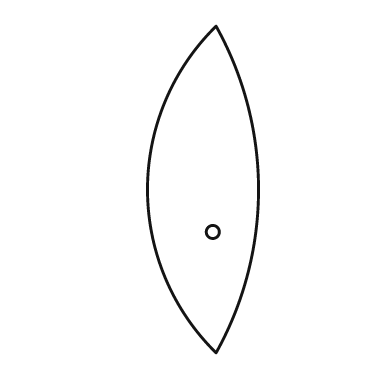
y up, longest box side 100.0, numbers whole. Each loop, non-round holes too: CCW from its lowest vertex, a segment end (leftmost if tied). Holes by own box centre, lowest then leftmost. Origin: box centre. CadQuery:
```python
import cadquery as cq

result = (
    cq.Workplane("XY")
    .moveTo(4.0, -50.0)
    .threePointArc((17.0, 0.0), (4.0, 50.0))
    .threePointArc((-17.0, 0.0), (4.0, -50.0))
    .close()
    .moveTo(3.0, -13.0)
    .circle(2.0)
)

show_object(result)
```